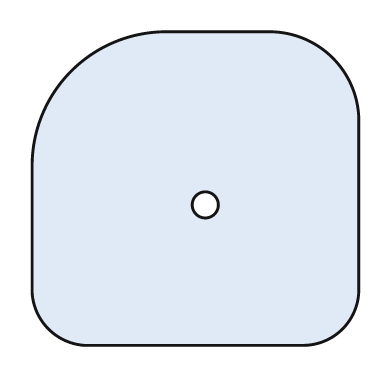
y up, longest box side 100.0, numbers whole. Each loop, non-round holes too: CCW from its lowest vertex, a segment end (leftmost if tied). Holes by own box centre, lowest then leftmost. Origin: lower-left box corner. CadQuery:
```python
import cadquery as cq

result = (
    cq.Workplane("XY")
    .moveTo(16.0, 0.0)
    .lineTo(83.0, 0.0)
    .threePointArc((95.0, 5.0), (100.0, 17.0))
    .lineTo(100.0, 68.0)
    .threePointArc((92.0, 88.0), (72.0, 96.0))
    .lineTo(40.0, 96.0)
    .threePointArc((12.0, 84.0), (0.0, 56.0))
    .lineTo(0.0, 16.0)
    .threePointArc((5.0, 5.0), (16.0, 0.0))
    .close()
    .moveTo(53.0, 43.0)
    .circle(4.0)
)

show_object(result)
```